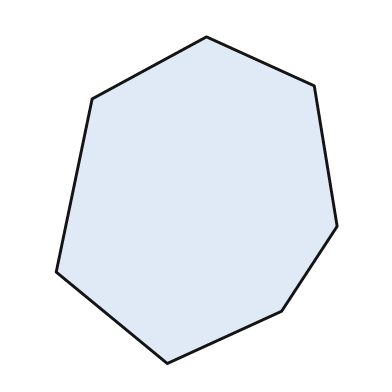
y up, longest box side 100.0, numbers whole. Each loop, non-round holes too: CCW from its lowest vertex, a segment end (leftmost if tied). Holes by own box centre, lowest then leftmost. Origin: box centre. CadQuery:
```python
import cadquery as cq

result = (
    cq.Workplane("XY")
    .moveTo(-9.0, -50.0)
    .lineTo(26.0, -34.0)
    .lineTo(43.0, -8.0)
    .lineTo(36.0, 35.0)
    .lineTo(3.0, 50.0)
    .lineTo(-32.0, 31.0)
    .lineTo(-43.0, -22.0)
    .close()
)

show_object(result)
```